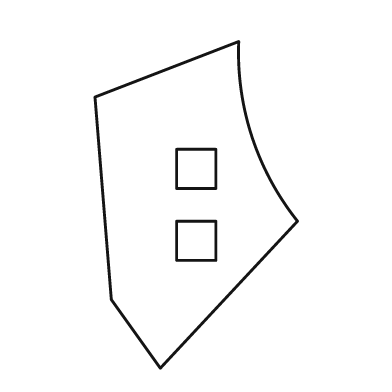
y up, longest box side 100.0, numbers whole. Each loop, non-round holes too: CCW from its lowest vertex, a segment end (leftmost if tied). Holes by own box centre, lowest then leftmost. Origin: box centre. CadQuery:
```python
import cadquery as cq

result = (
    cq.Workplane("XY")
    .moveTo(-11.0, -50.0)
    .lineTo(31.0, -5.0)
    .threePointArc((17.0, 21.0), (13.0, 50.0))
    .lineTo(-31.0, 33.0)
    .lineTo(-26.0, -29.0)
    .close()
    .moveTo(-6.0, -17.0)
    .lineTo(6.0, -17.0)
    .lineTo(6.0, -5.0)
    .lineTo(-6.0, -5.0)
    .close()
    .moveTo(-6.0, 5.0)
    .lineTo(6.0, 5.0)
    .lineTo(6.0, 17.0)
    .lineTo(-6.0, 17.0)
    .close()
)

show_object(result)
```